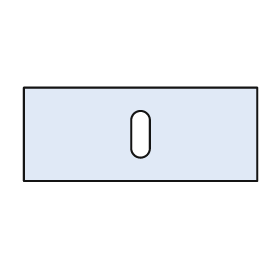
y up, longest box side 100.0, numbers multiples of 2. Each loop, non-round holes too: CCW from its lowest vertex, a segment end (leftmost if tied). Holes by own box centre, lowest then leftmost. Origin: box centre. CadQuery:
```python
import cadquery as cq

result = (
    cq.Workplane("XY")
    .moveTo(-50.0, -20.0)
    .lineTo(50.0, -20.0)
    .lineTo(50.0, 20.0)
    .lineTo(-50.0, 20.0)
    .close()
    .moveTo(-4.0, -6.0)
    .threePointArc((0.0, -10.0), (4.0, -6.0))
    .lineTo(4.0, 6.0)
    .threePointArc((0.0, 10.0), (-4.0, 6.0))
    .close()
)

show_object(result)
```